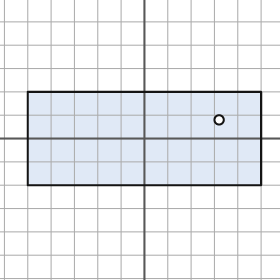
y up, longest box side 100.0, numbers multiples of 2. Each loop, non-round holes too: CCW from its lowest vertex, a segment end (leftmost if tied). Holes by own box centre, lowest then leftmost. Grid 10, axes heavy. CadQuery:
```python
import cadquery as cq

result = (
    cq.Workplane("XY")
    .moveTo(-50.0, -20.0)
    .lineTo(50.0, -20.0)
    .lineTo(50.0, 20.0)
    .lineTo(-50.0, 20.0)
    .close()
    .moveTo(32.0, 8.0)
    .circle(2.0)
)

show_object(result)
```